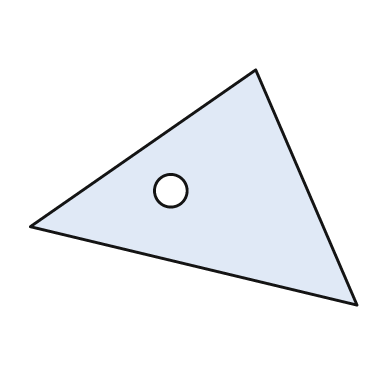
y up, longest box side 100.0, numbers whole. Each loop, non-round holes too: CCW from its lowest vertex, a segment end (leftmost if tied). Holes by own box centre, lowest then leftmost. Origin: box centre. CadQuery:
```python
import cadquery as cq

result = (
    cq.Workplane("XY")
    .moveTo(50.0, -36.0)
    .lineTo(19.0, 36.0)
    .lineTo(-50.0, -12.0)
    .close()
    .moveTo(-7.0, -1.0)
    .circle(5.0)
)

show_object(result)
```